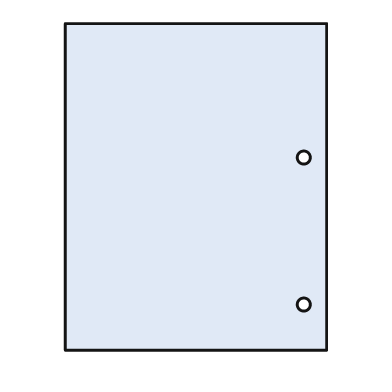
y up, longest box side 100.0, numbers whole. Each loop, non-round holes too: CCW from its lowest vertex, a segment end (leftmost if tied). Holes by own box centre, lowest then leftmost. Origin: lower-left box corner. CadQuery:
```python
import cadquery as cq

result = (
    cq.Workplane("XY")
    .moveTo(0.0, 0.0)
    .lineTo(80.0, 0.0)
    .lineTo(80.0, 100.0)
    .lineTo(0.0, 100.0)
    .close()
    .moveTo(73.0, 14.0)
    .circle(2.0)
    .moveTo(73.0, 59.0)
    .circle(2.0)
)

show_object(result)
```